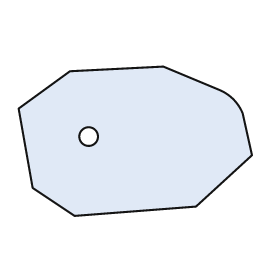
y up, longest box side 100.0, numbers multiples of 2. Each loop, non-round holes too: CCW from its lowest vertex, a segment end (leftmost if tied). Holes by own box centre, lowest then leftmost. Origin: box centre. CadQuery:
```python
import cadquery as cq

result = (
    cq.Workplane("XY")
    .moveTo(-26.0, -32.0)
    .lineTo(26.0, -28.0)
    .lineTo(50.0, -6.0)
    .lineTo(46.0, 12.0)
    .threePointArc((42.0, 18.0), (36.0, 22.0))
    .lineTo(12.0, 32.0)
    .lineTo(-28.0, 30.0)
    .lineTo(-50.0, 14.0)
    .lineTo(-44.0, -20.0)
    .close()
    .moveTo(-20.0, 2.0)
    .circle(4.0)
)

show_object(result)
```